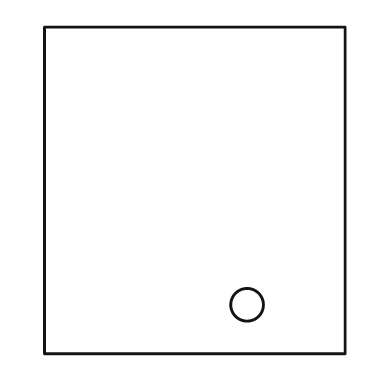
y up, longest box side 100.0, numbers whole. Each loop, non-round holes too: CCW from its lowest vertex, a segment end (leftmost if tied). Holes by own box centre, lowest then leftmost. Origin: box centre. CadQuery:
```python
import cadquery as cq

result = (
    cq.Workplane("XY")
    .moveTo(-46.0, -50.0)
    .lineTo(46.0, -50.0)
    .lineTo(46.0, 50.0)
    .lineTo(-46.0, 50.0)
    .close()
    .moveTo(16.0, -35.0)
    .circle(5.0)
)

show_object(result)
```